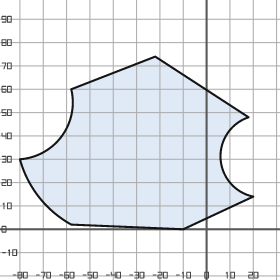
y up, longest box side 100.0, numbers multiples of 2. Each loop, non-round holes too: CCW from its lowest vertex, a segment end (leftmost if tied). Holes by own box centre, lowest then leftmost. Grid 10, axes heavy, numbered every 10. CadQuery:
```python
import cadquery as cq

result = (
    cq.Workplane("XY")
    .moveTo(-10.0, 0.0)
    .lineTo(20.0, 14.0)
    .threePointArc((6.0, 30.0), (18.0, 48.0))
    .lineTo(-22.0, 74.0)
    .lineTo(-58.0, 60.0)
    .threePointArc((-62.0, 40.0), (-80.0, 30.0))
    .threePointArc((-72.0, 14.0), (-58.0, 2.0))
    .close()
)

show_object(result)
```